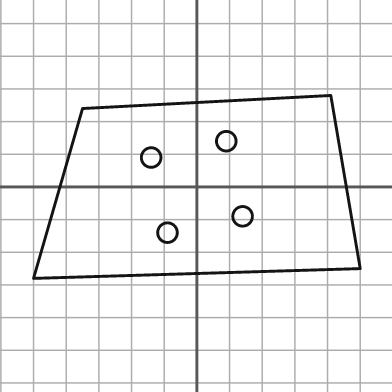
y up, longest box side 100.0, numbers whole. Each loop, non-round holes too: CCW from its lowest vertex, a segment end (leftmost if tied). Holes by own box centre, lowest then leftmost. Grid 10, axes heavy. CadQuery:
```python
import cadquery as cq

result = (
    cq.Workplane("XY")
    .moveTo(-50.0, -28.0)
    .lineTo(50.0, -25.0)
    .lineTo(41.0, 28.0)
    .lineTo(-35.0, 24.0)
    .close()
    .moveTo(-9.0, -14.0)
    .circle(3.0)
    .moveTo(14.0, -9.0)
    .circle(3.0)
    .moveTo(-14.0, 9.0)
    .circle(3.0)
    .moveTo(9.0, 14.0)
    .circle(3.0)
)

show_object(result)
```